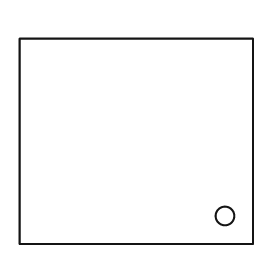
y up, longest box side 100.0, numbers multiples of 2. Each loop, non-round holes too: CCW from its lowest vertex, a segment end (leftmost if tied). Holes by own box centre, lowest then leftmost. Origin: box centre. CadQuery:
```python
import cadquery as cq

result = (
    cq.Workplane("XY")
    .moveTo(-50.0, -44.0)
    .lineTo(50.0, -44.0)
    .lineTo(50.0, 44.0)
    .lineTo(-50.0, 44.0)
    .close()
    .moveTo(38.0, -32.0)
    .circle(4.0)
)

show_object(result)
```